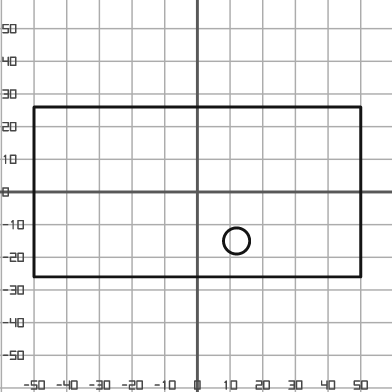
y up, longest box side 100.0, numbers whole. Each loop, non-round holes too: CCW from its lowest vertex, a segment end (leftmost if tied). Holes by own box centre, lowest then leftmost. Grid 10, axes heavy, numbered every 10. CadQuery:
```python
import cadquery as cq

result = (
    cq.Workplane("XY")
    .moveTo(-50.0, -26.0)
    .lineTo(50.0, -26.0)
    .lineTo(50.0, 26.0)
    .lineTo(-50.0, 26.0)
    .close()
    .moveTo(12.0, -15.0)
    .circle(4.0)
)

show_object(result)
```